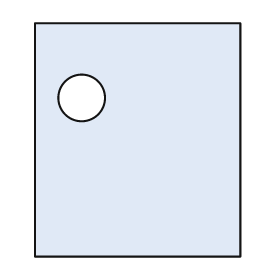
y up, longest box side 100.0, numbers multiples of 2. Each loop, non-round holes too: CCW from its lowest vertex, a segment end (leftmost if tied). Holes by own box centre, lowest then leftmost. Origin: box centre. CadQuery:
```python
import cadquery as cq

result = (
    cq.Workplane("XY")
    .moveTo(-44.0, -50.0)
    .lineTo(44.0, -50.0)
    .lineTo(44.0, 50.0)
    .lineTo(-44.0, 50.0)
    .close()
    .moveTo(-24.0, 18.0)
    .circle(10.0)
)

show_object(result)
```